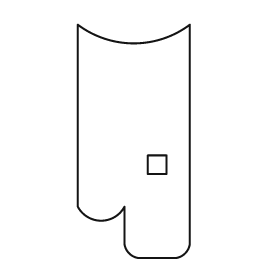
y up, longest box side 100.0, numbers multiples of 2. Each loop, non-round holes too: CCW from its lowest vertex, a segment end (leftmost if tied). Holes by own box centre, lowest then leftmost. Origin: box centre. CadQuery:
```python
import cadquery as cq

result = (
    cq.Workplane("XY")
    .moveTo(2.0, -50.0)
    .lineTo(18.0, -50.0)
    .threePointArc((22.0, -48.0), (24.0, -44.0))
    .lineTo(24.0, 50.0)
    .threePointArc((0.0, 42.0), (-24.0, 50.0))
    .lineTo(-24.0, -28.0)
    .threePointArc((-14.0, -34.0), (-4.0, -28.0))
    .lineTo(-4.0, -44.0)
    .threePointArc((-2.0, -48.0), (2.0, -50.0))
    .close()
    .moveTo(6.0, -14.0)
    .lineTo(14.0, -14.0)
    .lineTo(14.0, -6.0)
    .lineTo(6.0, -6.0)
    .close()
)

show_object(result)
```